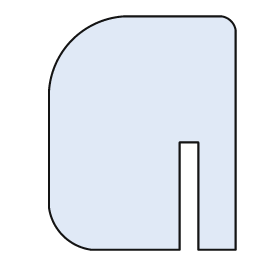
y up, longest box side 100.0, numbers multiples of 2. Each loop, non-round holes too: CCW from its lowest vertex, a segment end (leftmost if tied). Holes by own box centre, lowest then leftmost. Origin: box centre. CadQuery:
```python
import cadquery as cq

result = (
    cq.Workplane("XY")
    .moveTo(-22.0, -50.0)
    .lineTo(16.0, -50.0)
    .lineTo(16.0, -4.0)
    .lineTo(24.0, -4.0)
    .lineTo(24.0, -50.0)
    .lineTo(40.0, -50.0)
    .lineTo(40.0, 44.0)
    .threePointArc((38.0, 48.0), (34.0, 50.0))
    .lineTo(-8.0, 50.0)
    .threePointArc((-30.0, 40.0), (-40.0, 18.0))
    .lineTo(-40.0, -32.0)
    .threePointArc((-34.0, -44.0), (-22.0, -50.0))
    .close()
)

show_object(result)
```